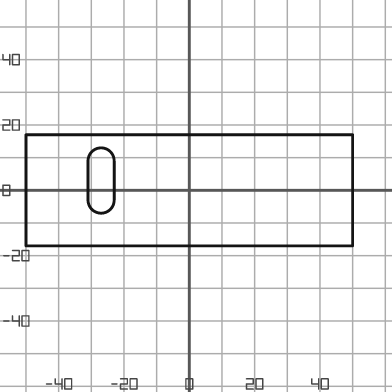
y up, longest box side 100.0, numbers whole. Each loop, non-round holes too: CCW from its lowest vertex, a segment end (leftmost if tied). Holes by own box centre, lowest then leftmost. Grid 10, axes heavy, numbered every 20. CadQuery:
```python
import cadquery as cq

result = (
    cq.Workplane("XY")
    .moveTo(-50.0, -17.0)
    .lineTo(50.0, -17.0)
    .lineTo(50.0, 17.0)
    .lineTo(-50.0, 17.0)
    .close()
    .moveTo(-31.0, -3.0)
    .threePointArc((-27.0, -7.0), (-23.0, -3.0))
    .lineTo(-23.0, 9.0)
    .threePointArc((-27.0, 13.0), (-31.0, 9.0))
    .close()
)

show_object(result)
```